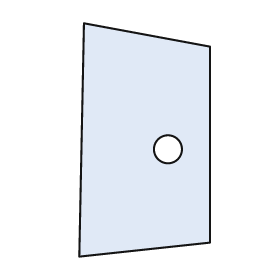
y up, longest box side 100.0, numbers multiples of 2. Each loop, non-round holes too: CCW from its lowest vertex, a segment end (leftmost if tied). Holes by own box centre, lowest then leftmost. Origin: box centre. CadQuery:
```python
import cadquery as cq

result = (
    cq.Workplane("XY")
    .moveTo(-28.0, -50.0)
    .lineTo(28.0, -44.0)
    .lineTo(28.0, 40.0)
    .lineTo(-26.0, 50.0)
    .close()
    .moveTo(10.0, -4.0)
    .circle(6.0)
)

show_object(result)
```